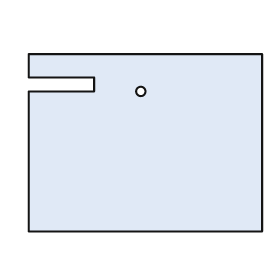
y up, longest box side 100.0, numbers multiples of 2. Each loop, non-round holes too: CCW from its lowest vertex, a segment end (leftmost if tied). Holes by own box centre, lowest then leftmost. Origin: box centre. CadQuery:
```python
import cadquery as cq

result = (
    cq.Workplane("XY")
    .moveTo(-50.0, -38.0)
    .lineTo(50.0, -38.0)
    .lineTo(50.0, 38.0)
    .lineTo(-50.0, 38.0)
    .lineTo(-50.0, 28.0)
    .lineTo(-22.0, 28.0)
    .lineTo(-22.0, 22.0)
    .lineTo(-50.0, 22.0)
    .close()
    .moveTo(-2.0, 22.0)
    .circle(2.0)
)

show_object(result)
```